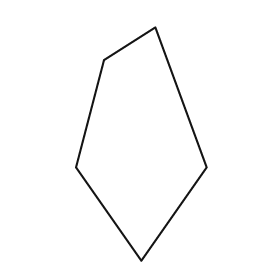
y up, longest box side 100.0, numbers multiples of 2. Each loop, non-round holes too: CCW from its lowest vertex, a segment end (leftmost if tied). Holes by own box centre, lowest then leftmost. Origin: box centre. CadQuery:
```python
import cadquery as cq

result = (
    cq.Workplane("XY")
    .moveTo(0.0, -50.0)
    .lineTo(28.0, -10.0)
    .lineTo(6.0, 50.0)
    .lineTo(-16.0, 36.0)
    .lineTo(-28.0, -10.0)
    .close()
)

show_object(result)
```